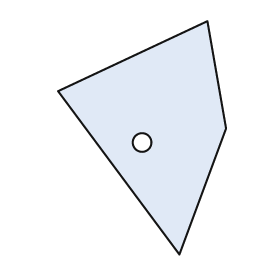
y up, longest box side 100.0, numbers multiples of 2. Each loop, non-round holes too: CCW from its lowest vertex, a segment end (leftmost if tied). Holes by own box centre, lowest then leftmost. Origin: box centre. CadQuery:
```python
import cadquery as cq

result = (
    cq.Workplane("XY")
    .moveTo(16.0, -50.0)
    .lineTo(36.0, 4.0)
    .lineTo(28.0, 50.0)
    .lineTo(-36.0, 20.0)
    .close()
    .moveTo(0.0, -2.0)
    .circle(4.0)
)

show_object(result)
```